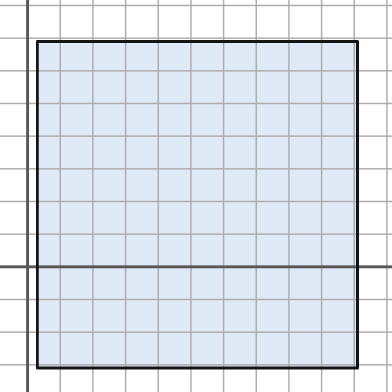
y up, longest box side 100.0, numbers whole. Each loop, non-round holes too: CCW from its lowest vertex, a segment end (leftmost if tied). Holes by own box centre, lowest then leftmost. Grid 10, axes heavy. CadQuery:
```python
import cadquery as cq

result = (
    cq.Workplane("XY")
    .moveTo(3.0, -31.0)
    .lineTo(101.0, -31.0)
    .lineTo(101.0, 69.0)
    .lineTo(3.0, 69.0)
    .close()
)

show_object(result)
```